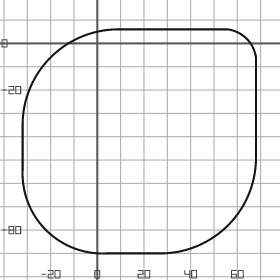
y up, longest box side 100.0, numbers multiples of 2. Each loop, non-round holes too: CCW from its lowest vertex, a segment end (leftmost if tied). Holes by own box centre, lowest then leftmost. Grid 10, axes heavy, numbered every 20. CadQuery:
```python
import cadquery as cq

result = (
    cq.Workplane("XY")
    .moveTo(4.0, -90.0)
    .lineTo(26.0, -90.0)
    .threePointArc((56.0, -78.0), (68.0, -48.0))
    .lineTo(68.0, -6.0)
    .threePointArc((64.0, 2.0), (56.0, 6.0))
    .lineTo(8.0, 6.0)
    .threePointArc((-20.0, -6.0), (-32.0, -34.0))
    .lineTo(-32.0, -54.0)
    .threePointArc((-22.0, -80.0), (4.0, -90.0))
    .close()
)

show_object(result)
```